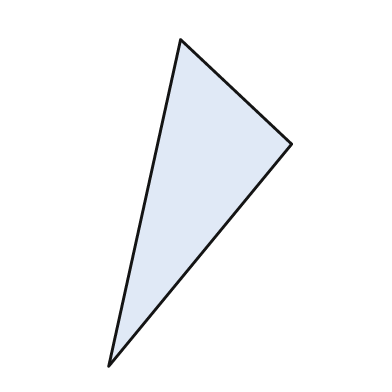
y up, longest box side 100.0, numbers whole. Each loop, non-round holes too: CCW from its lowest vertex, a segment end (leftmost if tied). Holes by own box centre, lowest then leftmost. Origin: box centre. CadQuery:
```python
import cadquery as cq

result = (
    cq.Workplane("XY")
    .moveTo(-28.0, -50.0)
    .lineTo(28.0, 18.0)
    .lineTo(-6.0, 50.0)
    .close()
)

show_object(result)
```